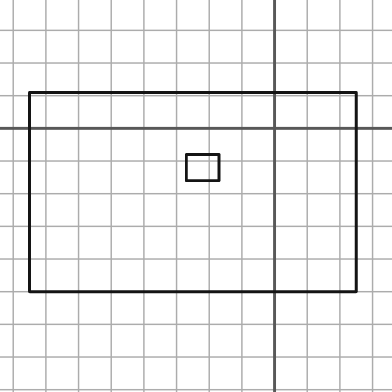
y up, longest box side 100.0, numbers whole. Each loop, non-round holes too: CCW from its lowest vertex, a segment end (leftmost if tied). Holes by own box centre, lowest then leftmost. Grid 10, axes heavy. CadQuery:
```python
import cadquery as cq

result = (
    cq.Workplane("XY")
    .moveTo(-75.0, -50.0)
    .lineTo(25.0, -50.0)
    .lineTo(25.0, 11.0)
    .lineTo(-75.0, 11.0)
    .close()
    .moveTo(-27.0, -16.0)
    .lineTo(-17.0, -16.0)
    .lineTo(-17.0, -8.0)
    .lineTo(-27.0, -8.0)
    .close()
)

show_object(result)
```